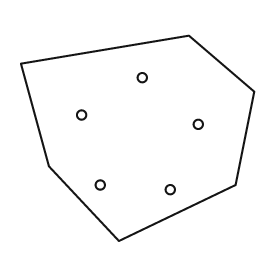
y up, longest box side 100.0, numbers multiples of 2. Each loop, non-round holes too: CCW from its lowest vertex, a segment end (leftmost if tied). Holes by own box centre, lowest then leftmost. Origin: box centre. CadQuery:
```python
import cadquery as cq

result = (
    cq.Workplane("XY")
    .moveTo(-8.0, -44.0)
    .lineTo(42.0, -20.0)
    .lineTo(50.0, 20.0)
    .lineTo(22.0, 44.0)
    .lineTo(-50.0, 32.0)
    .lineTo(-38.0, -12.0)
    .close()
    .moveTo(14.0, -22.0)
    .circle(2.0)
    .moveTo(-16.0, -20.0)
    .circle(2.0)
    .moveTo(26.0, 6.0)
    .circle(2.0)
    .moveTo(-24.0, 10.0)
    .circle(2.0)
    .moveTo(2.0, 26.0)
    .circle(2.0)
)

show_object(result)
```